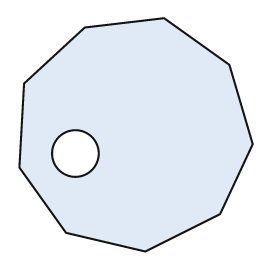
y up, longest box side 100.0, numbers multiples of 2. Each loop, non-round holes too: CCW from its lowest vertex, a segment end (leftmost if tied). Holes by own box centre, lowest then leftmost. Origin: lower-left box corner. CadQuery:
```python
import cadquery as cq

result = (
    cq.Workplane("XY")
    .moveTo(54.0, 0.0)
    .lineTo(86.0, 16.0)
    .lineTo(100.0, 46.0)
    .lineTo(90.0, 80.0)
    .lineTo(62.0, 100.0)
    .lineTo(28.0, 96.0)
    .lineTo(2.0, 72.0)
    .lineTo(0.0, 36.0)
    .lineTo(20.0, 8.0)
    .close()
    .moveTo(24.0, 42.0)
    .circle(10.0)
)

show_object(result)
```